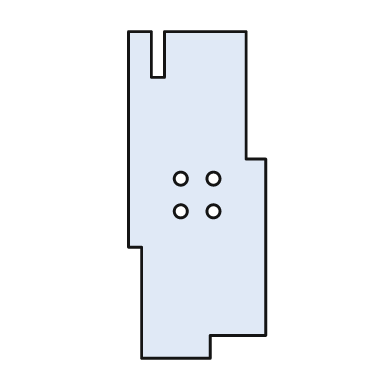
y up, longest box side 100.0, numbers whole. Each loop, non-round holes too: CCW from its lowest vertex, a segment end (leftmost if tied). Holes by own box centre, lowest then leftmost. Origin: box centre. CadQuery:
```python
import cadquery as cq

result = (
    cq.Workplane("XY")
    .moveTo(-17.0, -50.0)
    .lineTo(4.0, -50.0)
    .lineTo(4.0, -43.0)
    .lineTo(21.0, -43.0)
    .lineTo(21.0, 11.0)
    .lineTo(15.0, 11.0)
    .lineTo(15.0, 50.0)
    .lineTo(-10.0, 50.0)
    .lineTo(-10.0, 36.0)
    .lineTo(-14.0, 36.0)
    .lineTo(-14.0, 50.0)
    .lineTo(-21.0, 50.0)
    .lineTo(-21.0, -16.0)
    .lineTo(-17.0, -16.0)
    .close()
    .moveTo(-5.0, -5.0)
    .circle(2.0)
    .moveTo(5.0, -5.0)
    .circle(2.0)
    .moveTo(-5.0, 5.0)
    .circle(2.0)
    .moveTo(5.0, 5.0)
    .circle(2.0)
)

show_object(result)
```